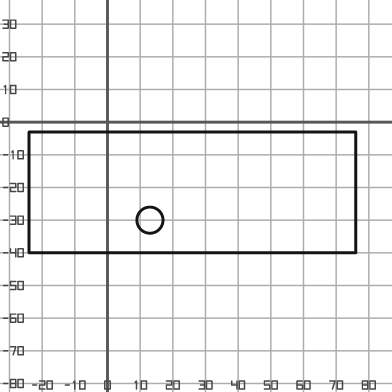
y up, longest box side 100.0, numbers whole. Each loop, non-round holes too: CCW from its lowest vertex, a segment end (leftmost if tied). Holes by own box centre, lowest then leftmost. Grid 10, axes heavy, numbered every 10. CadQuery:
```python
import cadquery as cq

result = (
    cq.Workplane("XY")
    .moveTo(-24.0, -40.0)
    .lineTo(76.0, -40.0)
    .lineTo(76.0, -3.0)
    .lineTo(-24.0, -3.0)
    .close()
    .moveTo(13.0, -30.0)
    .circle(4.0)
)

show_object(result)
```